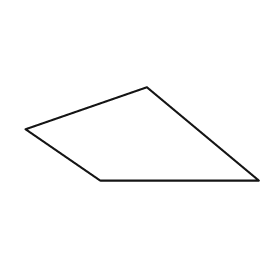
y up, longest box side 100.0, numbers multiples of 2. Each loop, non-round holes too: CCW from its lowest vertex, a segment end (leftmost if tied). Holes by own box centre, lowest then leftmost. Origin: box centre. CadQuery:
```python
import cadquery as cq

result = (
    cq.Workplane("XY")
    .moveTo(-18.0, -20.0)
    .lineTo(50.0, -20.0)
    .lineTo(2.0, 20.0)
    .lineTo(-50.0, 2.0)
    .close()
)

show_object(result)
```